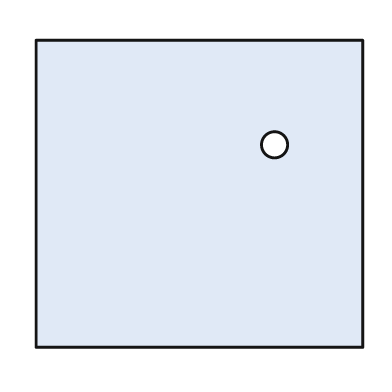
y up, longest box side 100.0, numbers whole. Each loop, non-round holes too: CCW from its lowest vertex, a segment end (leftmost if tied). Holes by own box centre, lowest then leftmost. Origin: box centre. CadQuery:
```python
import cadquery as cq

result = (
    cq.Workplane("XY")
    .moveTo(-50.0, -47.0)
    .lineTo(50.0, -47.0)
    .lineTo(50.0, 47.0)
    .lineTo(-50.0, 47.0)
    .close()
    .moveTo(23.0, 15.0)
    .circle(4.0)
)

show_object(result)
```